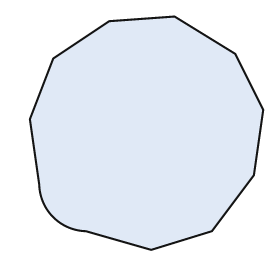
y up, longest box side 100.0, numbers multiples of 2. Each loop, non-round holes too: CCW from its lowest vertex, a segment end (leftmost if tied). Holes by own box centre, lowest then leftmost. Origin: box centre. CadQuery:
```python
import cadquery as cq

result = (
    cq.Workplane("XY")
    .moveTo(2.0, -50.0)
    .lineTo(28.0, -42.0)
    .lineTo(46.0, -18.0)
    .lineTo(50.0, 10.0)
    .lineTo(38.0, 34.0)
    .lineTo(12.0, 50.0)
    .lineTo(-16.0, 48.0)
    .lineTo(-40.0, 32.0)
    .lineTo(-50.0, 6.0)
    .lineTo(-46.0, -22.0)
    .threePointArc((-40.0, -36.0), (-26.0, -42.0))
    .close()
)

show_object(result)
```